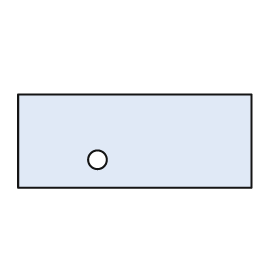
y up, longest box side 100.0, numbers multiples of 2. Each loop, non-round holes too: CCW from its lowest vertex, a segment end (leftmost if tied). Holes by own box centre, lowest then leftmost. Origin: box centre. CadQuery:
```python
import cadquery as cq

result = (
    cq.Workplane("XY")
    .moveTo(-50.0, -20.0)
    .lineTo(50.0, -20.0)
    .lineTo(50.0, 20.0)
    .lineTo(-50.0, 20.0)
    .close()
    .moveTo(-16.0, -8.0)
    .circle(4.0)
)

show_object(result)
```